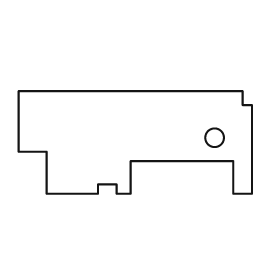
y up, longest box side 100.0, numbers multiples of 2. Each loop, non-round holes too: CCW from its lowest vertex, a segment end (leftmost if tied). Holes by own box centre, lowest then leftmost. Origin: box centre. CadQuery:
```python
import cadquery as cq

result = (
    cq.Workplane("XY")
    .moveTo(-38.0, -22.0)
    .lineTo(-16.0, -22.0)
    .lineTo(-16.0, -18.0)
    .lineTo(-8.0, -18.0)
    .lineTo(-8.0, -22.0)
    .lineTo(-2.0, -22.0)
    .lineTo(-2.0, -8.0)
    .lineTo(42.0, -8.0)
    .lineTo(42.0, -22.0)
    .lineTo(50.0, -22.0)
    .lineTo(50.0, 16.0)
    .lineTo(46.0, 16.0)
    .lineTo(46.0, 22.0)
    .lineTo(-50.0, 22.0)
    .lineTo(-50.0, -4.0)
    .lineTo(-38.0, -4.0)
    .close()
    .moveTo(34.0, 2.0)
    .circle(4.0)
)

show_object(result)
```